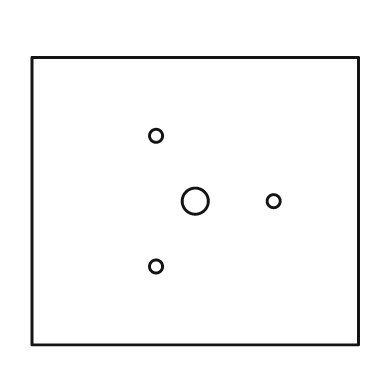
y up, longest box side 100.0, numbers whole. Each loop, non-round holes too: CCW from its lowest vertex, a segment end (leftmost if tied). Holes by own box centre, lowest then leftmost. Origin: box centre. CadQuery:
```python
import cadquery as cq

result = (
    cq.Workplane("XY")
    .moveTo(-50.0, -44.0)
    .lineTo(50.0, -44.0)
    .lineTo(50.0, 44.0)
    .lineTo(-50.0, 44.0)
    .close()
    .moveTo(-12.0, -20.0)
    .circle(2.0)
    .moveTo(0.0, 0.0)
    .circle(4.0)
    .moveTo(24.0, 0.0)
    .circle(2.0)
    .moveTo(-12.0, 20.0)
    .circle(2.0)
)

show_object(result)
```